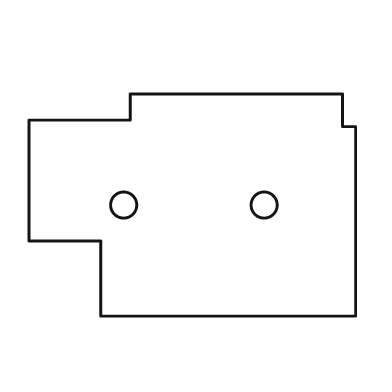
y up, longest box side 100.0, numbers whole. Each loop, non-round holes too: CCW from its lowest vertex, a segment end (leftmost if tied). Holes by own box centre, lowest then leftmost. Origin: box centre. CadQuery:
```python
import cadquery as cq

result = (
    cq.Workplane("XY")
    .moveTo(-28.0, -34.0)
    .lineTo(50.0, -34.0)
    .lineTo(50.0, 24.0)
    .lineTo(46.0, 24.0)
    .lineTo(46.0, 34.0)
    .lineTo(-19.0, 34.0)
    .lineTo(-19.0, 26.0)
    .lineTo(-50.0, 26.0)
    .lineTo(-50.0, -11.0)
    .lineTo(-28.0, -11.0)
    .close()
    .moveTo(-21.0, 0.0)
    .circle(4.0)
    .moveTo(22.0, 0.0)
    .circle(4.0)
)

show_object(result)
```